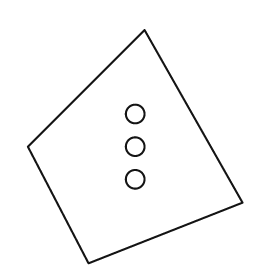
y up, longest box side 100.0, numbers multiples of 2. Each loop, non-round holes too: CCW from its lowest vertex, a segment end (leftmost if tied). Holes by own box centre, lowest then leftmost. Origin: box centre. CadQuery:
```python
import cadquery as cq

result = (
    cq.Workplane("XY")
    .moveTo(-20.0, -50.0)
    .lineTo(46.0, -24.0)
    .lineTo(4.0, 50.0)
    .lineTo(-46.0, 0.0)
    .close()
    .moveTo(0.0, -14.0)
    .circle(4.0)
    .moveTo(0.0, 0.0)
    .circle(4.0)
    .moveTo(0.0, 14.0)
    .circle(4.0)
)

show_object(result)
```